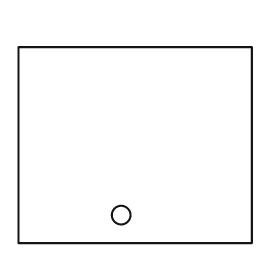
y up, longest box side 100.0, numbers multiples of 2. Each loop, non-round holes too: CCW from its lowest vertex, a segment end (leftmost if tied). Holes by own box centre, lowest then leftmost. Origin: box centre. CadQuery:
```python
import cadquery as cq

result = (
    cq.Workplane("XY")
    .moveTo(-50.0, -42.0)
    .lineTo(50.0, -42.0)
    .lineTo(50.0, 42.0)
    .lineTo(-50.0, 42.0)
    .close()
    .moveTo(-6.0, -30.0)
    .circle(4.0)
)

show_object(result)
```